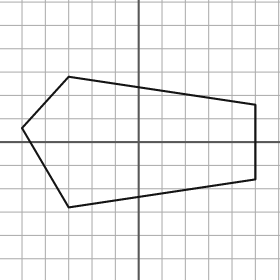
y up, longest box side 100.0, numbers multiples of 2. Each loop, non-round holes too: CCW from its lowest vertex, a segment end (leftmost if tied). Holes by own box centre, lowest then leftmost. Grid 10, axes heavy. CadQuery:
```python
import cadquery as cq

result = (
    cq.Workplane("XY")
    .moveTo(-30.0, -28.0)
    .lineTo(50.0, -16.0)
    .lineTo(50.0, 16.0)
    .lineTo(-30.0, 28.0)
    .lineTo(-50.0, 6.0)
    .close()
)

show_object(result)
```